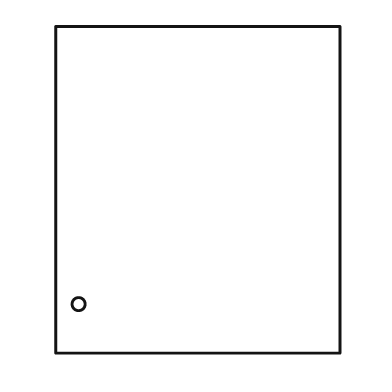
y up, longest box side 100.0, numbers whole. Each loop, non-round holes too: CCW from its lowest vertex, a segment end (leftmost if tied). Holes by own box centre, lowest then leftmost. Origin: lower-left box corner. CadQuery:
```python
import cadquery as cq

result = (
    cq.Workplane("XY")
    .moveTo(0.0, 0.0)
    .lineTo(87.0, 0.0)
    .lineTo(87.0, 100.0)
    .lineTo(0.0, 100.0)
    .close()
    .moveTo(7.0, 15.0)
    .circle(2.0)
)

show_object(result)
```